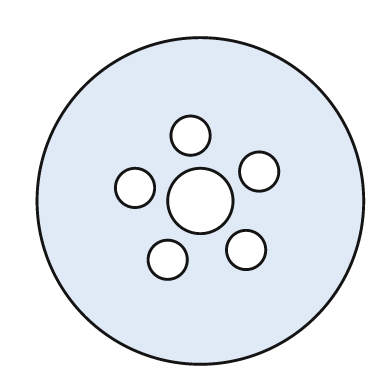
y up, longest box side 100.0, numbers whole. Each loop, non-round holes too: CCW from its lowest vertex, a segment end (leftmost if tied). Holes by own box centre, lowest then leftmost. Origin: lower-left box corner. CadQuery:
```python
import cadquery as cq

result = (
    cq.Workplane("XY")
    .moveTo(50.0, 50.0)
    .circle(50.0)
    .moveTo(40.0, 32.0)
    .circle(6.0)
    .moveTo(64.0, 35.0)
    .circle(6.0)
    .moveTo(50.0, 50.0)
    .circle(10.0)
    .moveTo(30.0, 54.0)
    .circle(6.0)
    .moveTo(68.0, 59.0)
    .circle(6.0)
    .moveTo(47.0, 70.0)
    .circle(6.0)
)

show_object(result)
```